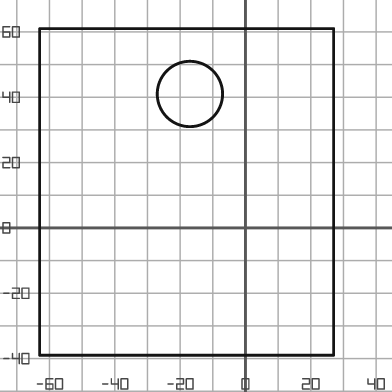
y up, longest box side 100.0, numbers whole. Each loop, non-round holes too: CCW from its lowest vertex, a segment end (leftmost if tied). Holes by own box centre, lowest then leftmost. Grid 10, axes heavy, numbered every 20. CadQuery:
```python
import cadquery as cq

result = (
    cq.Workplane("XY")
    .moveTo(-63.0, -39.0)
    .lineTo(27.0, -39.0)
    .lineTo(27.0, 61.0)
    .lineTo(-63.0, 61.0)
    .close()
    .moveTo(-17.0, 41.0)
    .circle(10.0)
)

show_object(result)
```